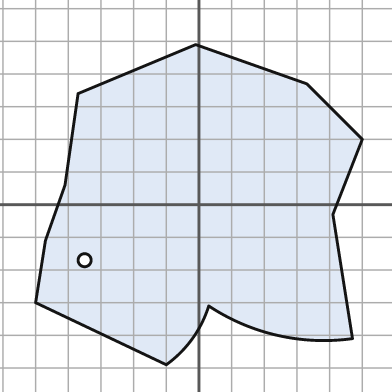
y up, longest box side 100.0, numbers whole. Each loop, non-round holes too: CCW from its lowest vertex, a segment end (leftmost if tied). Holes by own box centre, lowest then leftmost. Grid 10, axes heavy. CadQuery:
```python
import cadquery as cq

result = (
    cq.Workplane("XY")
    .moveTo(-10.0, -49.0)
    .threePointArc((-2.0, -41.0), (3.0, -31.0))
    .threePointArc((24.0, -40.0), (47.0, -41.0))
    .lineTo(41.0, -3.0)
    .lineTo(50.0, 20.0)
    .lineTo(33.0, 37.0)
    .lineTo(-1.0, 49.0)
    .lineTo(-37.0, 34.0)
    .lineTo(-41.0, 6.0)
    .lineTo(-47.0, -11.0)
    .lineTo(-50.0, -30.0)
    .close()
    .moveTo(-35.0, -17.0)
    .circle(2.0)
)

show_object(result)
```